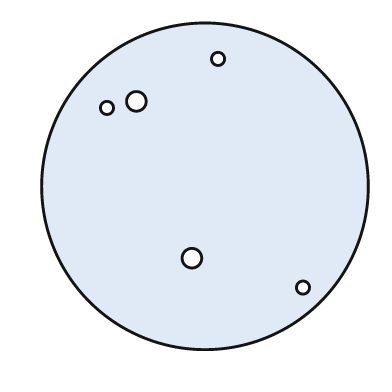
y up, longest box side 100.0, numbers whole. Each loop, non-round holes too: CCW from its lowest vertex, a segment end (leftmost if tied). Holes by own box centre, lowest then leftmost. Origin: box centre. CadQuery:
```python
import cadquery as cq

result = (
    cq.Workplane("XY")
    .moveTo(0.0, 0.0)
    .circle(50.0)
    .moveTo(30.0, -31.0)
    .circle(2.0)
    .moveTo(-4.0, -22.0)
    .circle(3.0)
    .moveTo(-30.0, 24.0)
    .circle(2.0)
    .moveTo(-21.0, 26.0)
    .circle(3.0)
    .moveTo(4.0, 39.0)
    .circle(2.0)
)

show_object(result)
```